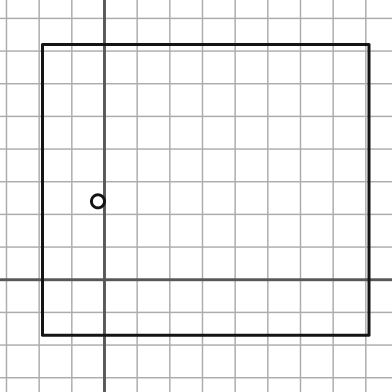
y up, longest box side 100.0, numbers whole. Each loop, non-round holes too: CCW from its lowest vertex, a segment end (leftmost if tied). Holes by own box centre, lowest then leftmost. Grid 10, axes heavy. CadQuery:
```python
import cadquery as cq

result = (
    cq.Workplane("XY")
    .moveTo(-19.0, -17.0)
    .lineTo(81.0, -17.0)
    .lineTo(81.0, 72.0)
    .lineTo(-19.0, 72.0)
    .close()
    .moveTo(-2.0, 24.0)
    .circle(2.0)
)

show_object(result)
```